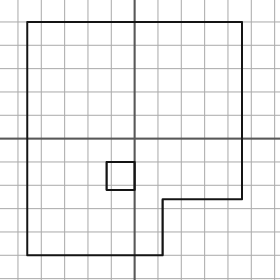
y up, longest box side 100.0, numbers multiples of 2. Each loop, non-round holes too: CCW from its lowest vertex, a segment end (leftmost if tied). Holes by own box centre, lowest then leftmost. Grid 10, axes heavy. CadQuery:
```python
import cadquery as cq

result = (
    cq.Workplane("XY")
    .moveTo(-46.0, -50.0)
    .lineTo(12.0, -50.0)
    .lineTo(12.0, -26.0)
    .lineTo(46.0, -26.0)
    .lineTo(46.0, 50.0)
    .lineTo(-46.0, 50.0)
    .close()
    .moveTo(-12.0, -22.0)
    .lineTo(0.0, -22.0)
    .lineTo(0.0, -10.0)
    .lineTo(-12.0, -10.0)
    .close()
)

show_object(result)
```